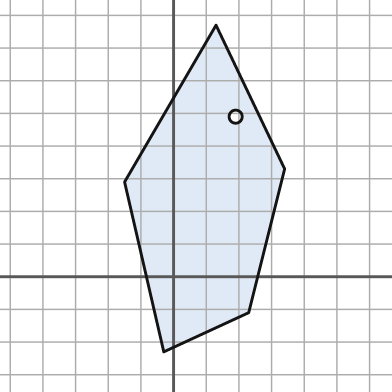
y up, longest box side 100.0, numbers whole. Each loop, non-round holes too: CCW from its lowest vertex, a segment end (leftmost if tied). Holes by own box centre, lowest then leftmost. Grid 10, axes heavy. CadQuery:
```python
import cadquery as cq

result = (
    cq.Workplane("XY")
    .moveTo(-3.0, -23.0)
    .lineTo(23.0, -11.0)
    .lineTo(34.0, 33.0)
    .lineTo(13.0, 77.0)
    .lineTo(-15.0, 29.0)
    .close()
    .moveTo(19.0, 49.0)
    .circle(2.0)
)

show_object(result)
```